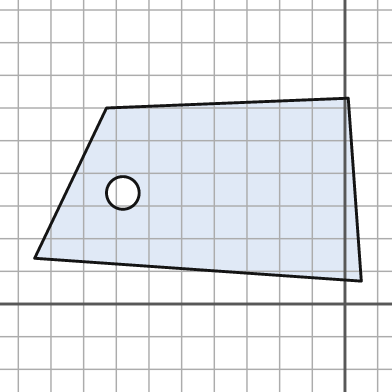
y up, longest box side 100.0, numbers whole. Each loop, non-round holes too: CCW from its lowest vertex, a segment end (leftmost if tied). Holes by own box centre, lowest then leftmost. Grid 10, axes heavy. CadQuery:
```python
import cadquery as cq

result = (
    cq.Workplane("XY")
    .moveTo(5.0, 7.0)
    .lineTo(1.0, 63.0)
    .lineTo(-73.0, 60.0)
    .lineTo(-95.0, 14.0)
    .close()
    .moveTo(-68.0, 34.0)
    .circle(5.0)
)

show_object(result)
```